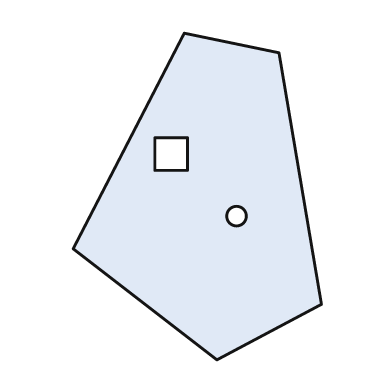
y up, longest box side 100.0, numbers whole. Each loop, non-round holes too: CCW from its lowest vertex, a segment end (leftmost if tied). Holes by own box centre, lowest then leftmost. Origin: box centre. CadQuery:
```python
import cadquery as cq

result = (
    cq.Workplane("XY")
    .moveTo(6.0, -50.0)
    .lineTo(38.0, -33.0)
    .lineTo(25.0, 44.0)
    .lineTo(-4.0, 50.0)
    .lineTo(-38.0, -16.0)
    .close()
    .moveTo(12.0, -6.0)
    .circle(3.0)
    .moveTo(-13.0, 8.0)
    .lineTo(-3.0, 8.0)
    .lineTo(-3.0, 18.0)
    .lineTo(-13.0, 18.0)
    .close()
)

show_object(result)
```